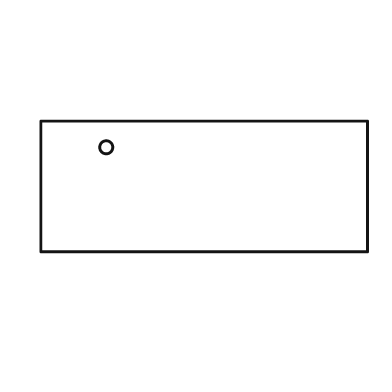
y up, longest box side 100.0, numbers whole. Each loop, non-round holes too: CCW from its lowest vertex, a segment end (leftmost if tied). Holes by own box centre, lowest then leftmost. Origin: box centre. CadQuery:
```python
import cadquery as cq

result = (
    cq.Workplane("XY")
    .moveTo(-50.0, -20.0)
    .lineTo(50.0, -20.0)
    .lineTo(50.0, 20.0)
    .lineTo(-50.0, 20.0)
    .close()
    .moveTo(-30.0, 12.0)
    .circle(2.0)
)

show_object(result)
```